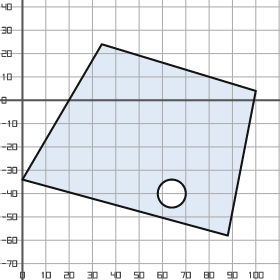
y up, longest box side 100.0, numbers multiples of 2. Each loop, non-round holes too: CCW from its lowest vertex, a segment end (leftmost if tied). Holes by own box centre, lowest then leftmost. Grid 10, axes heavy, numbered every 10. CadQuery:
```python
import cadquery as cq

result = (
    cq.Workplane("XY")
    .moveTo(88.0, -58.0)
    .lineTo(100.0, 4.0)
    .lineTo(34.0, 24.0)
    .lineTo(0.0, -34.0)
    .close()
    .moveTo(64.0, -40.0)
    .circle(6.0)
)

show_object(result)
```